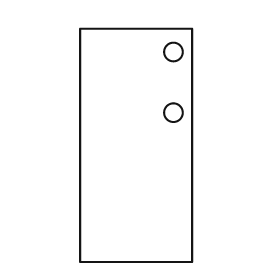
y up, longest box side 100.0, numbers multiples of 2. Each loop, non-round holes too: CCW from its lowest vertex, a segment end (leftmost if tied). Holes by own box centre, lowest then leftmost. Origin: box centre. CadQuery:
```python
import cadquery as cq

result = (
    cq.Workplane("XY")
    .moveTo(-24.0, -50.0)
    .lineTo(24.0, -50.0)
    .lineTo(24.0, 50.0)
    .lineTo(-24.0, 50.0)
    .close()
    .moveTo(16.0, 14.0)
    .circle(4.0)
    .moveTo(16.0, 40.0)
    .circle(4.0)
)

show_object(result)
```